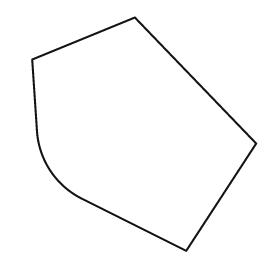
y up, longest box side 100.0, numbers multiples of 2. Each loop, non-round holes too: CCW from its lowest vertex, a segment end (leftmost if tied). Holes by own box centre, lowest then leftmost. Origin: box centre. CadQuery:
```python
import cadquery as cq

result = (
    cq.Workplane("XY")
    .moveTo(18.0, -50.0)
    .lineTo(48.0, -4.0)
    .lineTo(-4.0, 50.0)
    .lineTo(-48.0, 32.0)
    .lineTo(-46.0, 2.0)
    .threePointArc((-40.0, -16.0), (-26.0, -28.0))
    .close()
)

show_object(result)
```